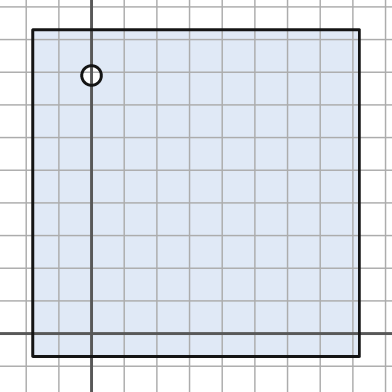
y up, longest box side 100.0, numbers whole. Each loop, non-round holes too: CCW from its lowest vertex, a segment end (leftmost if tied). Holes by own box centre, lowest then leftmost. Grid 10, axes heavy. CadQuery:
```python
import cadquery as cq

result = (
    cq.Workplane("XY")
    .moveTo(-18.0, -7.0)
    .lineTo(82.0, -7.0)
    .lineTo(82.0, 93.0)
    .lineTo(-18.0, 93.0)
    .close()
    .moveTo(0.0, 79.0)
    .circle(3.0)
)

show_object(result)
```